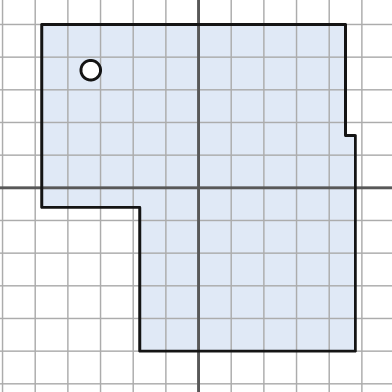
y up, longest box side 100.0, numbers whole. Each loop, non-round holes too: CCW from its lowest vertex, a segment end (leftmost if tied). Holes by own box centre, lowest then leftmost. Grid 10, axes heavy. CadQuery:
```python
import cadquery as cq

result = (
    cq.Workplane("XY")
    .moveTo(-18.0, -50.0)
    .lineTo(48.0, -50.0)
    .lineTo(48.0, 16.0)
    .lineTo(45.0, 16.0)
    .lineTo(45.0, 50.0)
    .lineTo(-48.0, 50.0)
    .lineTo(-48.0, -6.0)
    .lineTo(-18.0, -6.0)
    .close()
    .moveTo(-33.0, 36.0)
    .circle(3.0)
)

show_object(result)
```